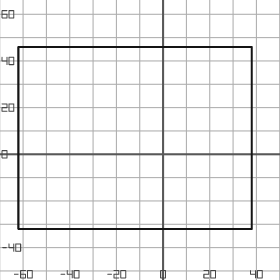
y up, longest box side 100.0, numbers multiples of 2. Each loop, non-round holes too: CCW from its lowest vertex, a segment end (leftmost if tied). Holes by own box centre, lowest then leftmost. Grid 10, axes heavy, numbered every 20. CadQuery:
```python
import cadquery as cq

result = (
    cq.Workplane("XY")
    .moveTo(-62.0, -32.0)
    .lineTo(38.0, -32.0)
    .lineTo(38.0, 46.0)
    .lineTo(-62.0, 46.0)
    .close()
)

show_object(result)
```